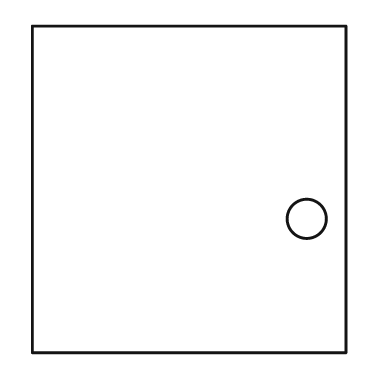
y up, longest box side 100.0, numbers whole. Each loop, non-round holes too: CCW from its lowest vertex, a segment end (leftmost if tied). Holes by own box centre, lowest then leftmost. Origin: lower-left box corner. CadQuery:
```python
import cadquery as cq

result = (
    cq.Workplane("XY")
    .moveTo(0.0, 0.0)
    .lineTo(96.0, 0.0)
    .lineTo(96.0, 100.0)
    .lineTo(0.0, 100.0)
    .close()
    .moveTo(84.0, 41.0)
    .circle(6.0)
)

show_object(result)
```